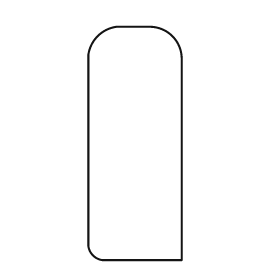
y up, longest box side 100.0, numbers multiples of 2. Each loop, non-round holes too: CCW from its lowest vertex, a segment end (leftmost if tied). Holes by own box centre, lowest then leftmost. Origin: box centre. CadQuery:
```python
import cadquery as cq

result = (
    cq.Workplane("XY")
    .moveTo(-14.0, -50.0)
    .lineTo(20.0, -50.0)
    .lineTo(20.0, 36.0)
    .threePointArc((16.0, 46.0), (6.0, 50.0))
    .lineTo(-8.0, 50.0)
    .threePointArc((-16.0, 46.0), (-20.0, 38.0))
    .lineTo(-20.0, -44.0)
    .threePointArc((-18.0, -48.0), (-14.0, -50.0))
    .close()
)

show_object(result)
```